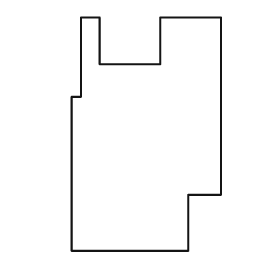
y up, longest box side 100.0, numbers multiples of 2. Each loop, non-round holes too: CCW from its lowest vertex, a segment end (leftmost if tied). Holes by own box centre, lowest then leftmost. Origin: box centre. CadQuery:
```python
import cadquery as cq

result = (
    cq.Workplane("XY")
    .moveTo(-32.0, -50.0)
    .lineTo(18.0, -50.0)
    .lineTo(18.0, -26.0)
    .lineTo(32.0, -26.0)
    .lineTo(32.0, 50.0)
    .lineTo(6.0, 50.0)
    .lineTo(6.0, 30.0)
    .lineTo(-20.0, 30.0)
    .lineTo(-20.0, 50.0)
    .lineTo(-28.0, 50.0)
    .lineTo(-28.0, 16.0)
    .lineTo(-32.0, 16.0)
    .close()
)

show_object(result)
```